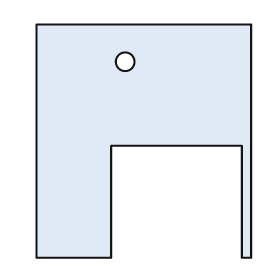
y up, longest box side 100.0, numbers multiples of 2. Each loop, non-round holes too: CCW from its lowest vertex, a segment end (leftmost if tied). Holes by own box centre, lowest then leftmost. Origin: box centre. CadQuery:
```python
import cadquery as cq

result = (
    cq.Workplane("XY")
    .moveTo(-46.0, -50.0)
    .lineTo(-14.0, -50.0)
    .lineTo(-14.0, -2.0)
    .lineTo(42.0, -2.0)
    .lineTo(42.0, -50.0)
    .lineTo(46.0, -50.0)
    .lineTo(46.0, 50.0)
    .lineTo(-46.0, 50.0)
    .close()
    .moveTo(-8.0, 34.0)
    .circle(4.0)
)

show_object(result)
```